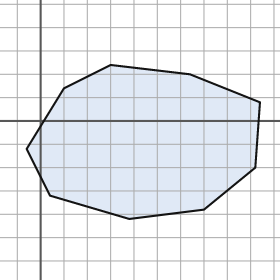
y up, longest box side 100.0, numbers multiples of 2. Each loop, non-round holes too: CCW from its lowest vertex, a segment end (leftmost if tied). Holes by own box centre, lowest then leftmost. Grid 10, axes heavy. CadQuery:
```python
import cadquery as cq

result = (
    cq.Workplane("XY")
    .moveTo(38.0, -42.0)
    .lineTo(70.0, -38.0)
    .lineTo(92.0, -20.0)
    .lineTo(94.0, 8.0)
    .lineTo(64.0, 20.0)
    .lineTo(30.0, 24.0)
    .lineTo(10.0, 14.0)
    .lineTo(-6.0, -12.0)
    .lineTo(4.0, -32.0)
    .close()
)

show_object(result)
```